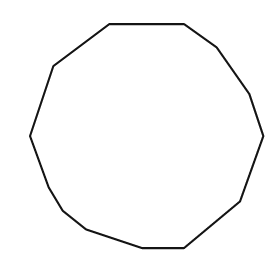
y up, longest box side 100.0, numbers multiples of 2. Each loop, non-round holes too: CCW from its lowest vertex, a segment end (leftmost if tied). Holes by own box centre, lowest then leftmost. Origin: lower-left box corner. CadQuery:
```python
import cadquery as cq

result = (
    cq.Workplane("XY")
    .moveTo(48.0, 0.0)
    .lineTo(66.0, 0.0)
    .lineTo(90.0, 20.0)
    .lineTo(100.0, 48.0)
    .lineTo(94.0, 66.0)
    .lineTo(80.0, 86.0)
    .lineTo(66.0, 96.0)
    .lineTo(34.0, 96.0)
    .lineTo(10.0, 78.0)
    .lineTo(0.0, 48.0)
    .lineTo(8.0, 26.0)
    .lineTo(14.0, 16.0)
    .lineTo(24.0, 8.0)
    .close()
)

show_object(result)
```